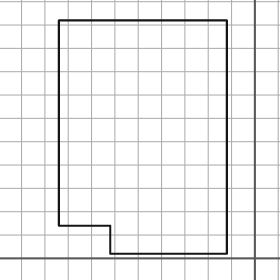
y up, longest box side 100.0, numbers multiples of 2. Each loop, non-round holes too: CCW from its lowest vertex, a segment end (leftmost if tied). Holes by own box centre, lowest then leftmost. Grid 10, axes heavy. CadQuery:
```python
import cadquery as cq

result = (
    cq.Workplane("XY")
    .moveTo(-62.0, 2.0)
    .lineTo(-12.0, 2.0)
    .lineTo(-12.0, 102.0)
    .lineTo(-84.0, 102.0)
    .lineTo(-84.0, 14.0)
    .lineTo(-62.0, 14.0)
    .close()
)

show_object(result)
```